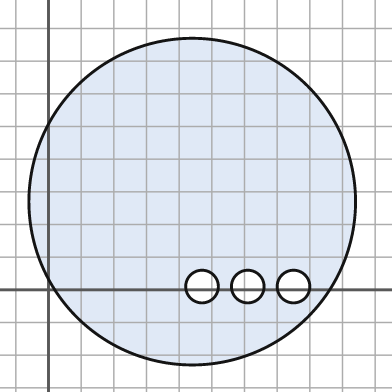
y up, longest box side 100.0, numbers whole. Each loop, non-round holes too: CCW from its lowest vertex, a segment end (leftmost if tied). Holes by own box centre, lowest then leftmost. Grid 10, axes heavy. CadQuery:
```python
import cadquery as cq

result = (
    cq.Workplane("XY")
    .moveTo(44.0, 27.0)
    .circle(50.0)
    .moveTo(47.0, 1.0)
    .circle(5.0)
    .moveTo(61.0, 1.0)
    .circle(5.0)
    .moveTo(75.0, 1.0)
    .circle(5.0)
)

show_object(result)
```